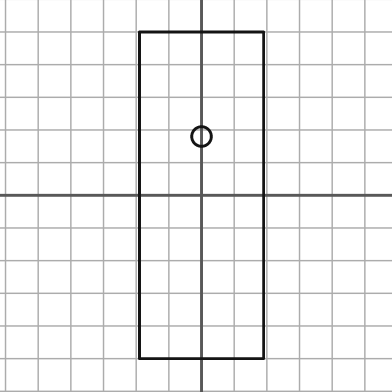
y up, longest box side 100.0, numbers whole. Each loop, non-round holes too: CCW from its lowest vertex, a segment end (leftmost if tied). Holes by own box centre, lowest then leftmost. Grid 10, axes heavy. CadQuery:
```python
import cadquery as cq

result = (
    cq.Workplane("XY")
    .moveTo(-19.0, -50.0)
    .lineTo(19.0, -50.0)
    .lineTo(19.0, 50.0)
    .lineTo(-19.0, 50.0)
    .close()
    .moveTo(0.0, 18.0)
    .circle(3.0)
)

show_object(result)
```